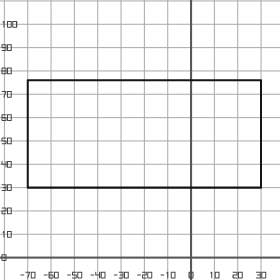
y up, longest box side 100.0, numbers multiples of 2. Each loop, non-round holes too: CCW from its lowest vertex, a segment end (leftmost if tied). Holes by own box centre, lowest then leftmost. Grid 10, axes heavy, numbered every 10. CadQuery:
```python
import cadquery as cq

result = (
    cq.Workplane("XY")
    .moveTo(-70.0, 30.0)
    .lineTo(30.0, 30.0)
    .lineTo(30.0, 76.0)
    .lineTo(-70.0, 76.0)
    .close()
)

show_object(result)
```